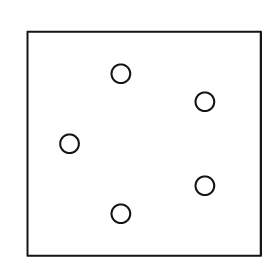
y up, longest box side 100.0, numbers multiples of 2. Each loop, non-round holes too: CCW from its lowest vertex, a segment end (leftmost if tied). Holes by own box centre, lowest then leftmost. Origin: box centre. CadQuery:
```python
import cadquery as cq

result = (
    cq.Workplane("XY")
    .moveTo(-50.0, -48.0)
    .lineTo(50.0, -48.0)
    .lineTo(50.0, 48.0)
    .lineTo(-50.0, 48.0)
    .close()
    .moveTo(-10.0, -30.0)
    .circle(4.0)
    .moveTo(26.0, -18.0)
    .circle(4.0)
    .moveTo(-32.0, 0.0)
    .circle(4.0)
    .moveTo(26.0, 18.0)
    .circle(4.0)
    .moveTo(-10.0, 30.0)
    .circle(4.0)
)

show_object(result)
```